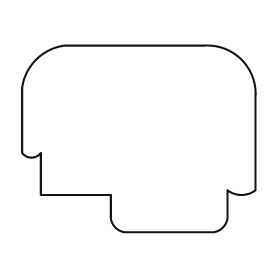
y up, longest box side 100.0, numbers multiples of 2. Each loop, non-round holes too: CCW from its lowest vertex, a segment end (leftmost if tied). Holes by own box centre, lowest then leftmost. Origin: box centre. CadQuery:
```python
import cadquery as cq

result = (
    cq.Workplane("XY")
    .moveTo(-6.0, -40.0)
    .lineTo(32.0, -40.0)
    .threePointArc((36.0, -38.0), (38.0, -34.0))
    .lineTo(38.0, -22.0)
    .threePointArc((44.0, -24.0), (50.0, -22.0))
    .lineTo(50.0, 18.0)
    .threePointArc((44.0, 34.0), (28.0, 40.0))
    .lineTo(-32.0, 40.0)
    .threePointArc((-44.0, 34.0), (-50.0, 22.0))
    .lineTo(-50.0, -6.0)
    .threePointArc((-46.0, -8.0), (-42.0, -6.0))
    .lineTo(-42.0, -24.0)
    .lineTo(-12.0, -24.0)
    .lineTo(-12.0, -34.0)
    .threePointArc((-10.0, -38.0), (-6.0, -40.0))
    .close()
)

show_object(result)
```